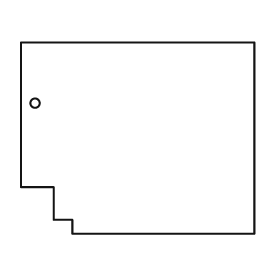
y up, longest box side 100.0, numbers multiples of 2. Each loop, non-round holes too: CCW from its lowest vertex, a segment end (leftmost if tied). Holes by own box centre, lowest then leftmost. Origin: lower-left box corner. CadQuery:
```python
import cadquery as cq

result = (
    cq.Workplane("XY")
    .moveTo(22.0, 0.0)
    .lineTo(100.0, 0.0)
    .lineTo(100.0, 82.0)
    .lineTo(0.0, 82.0)
    .lineTo(0.0, 20.0)
    .lineTo(14.0, 20.0)
    .lineTo(14.0, 6.0)
    .lineTo(22.0, 6.0)
    .close()
    .moveTo(6.0, 56.0)
    .circle(2.0)
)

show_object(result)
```